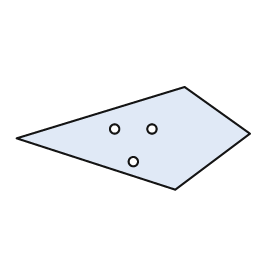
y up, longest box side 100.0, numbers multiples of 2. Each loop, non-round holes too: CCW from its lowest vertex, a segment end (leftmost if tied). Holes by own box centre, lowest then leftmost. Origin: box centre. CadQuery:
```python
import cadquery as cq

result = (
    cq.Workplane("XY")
    .moveTo(18.0, -22.0)
    .lineTo(50.0, 2.0)
    .lineTo(22.0, 22.0)
    .lineTo(-50.0, 0.0)
    .close()
    .moveTo(0.0, -10.0)
    .circle(2.0)
    .moveTo(-8.0, 4.0)
    .circle(2.0)
    .moveTo(8.0, 4.0)
    .circle(2.0)
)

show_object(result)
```